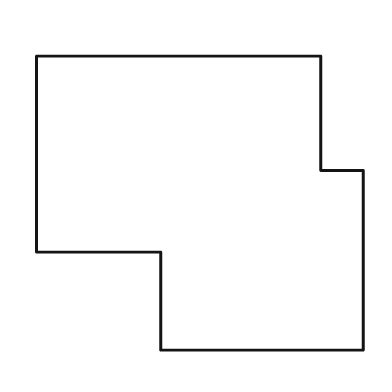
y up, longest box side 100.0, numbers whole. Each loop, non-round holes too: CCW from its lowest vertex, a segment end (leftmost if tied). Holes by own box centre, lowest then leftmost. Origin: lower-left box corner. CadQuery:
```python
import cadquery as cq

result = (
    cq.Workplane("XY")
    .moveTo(38.0, 0.0)
    .lineTo(100.0, 0.0)
    .lineTo(100.0, 55.0)
    .lineTo(87.0, 55.0)
    .lineTo(87.0, 90.0)
    .lineTo(0.0, 90.0)
    .lineTo(0.0, 30.0)
    .lineTo(38.0, 30.0)
    .close()
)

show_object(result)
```